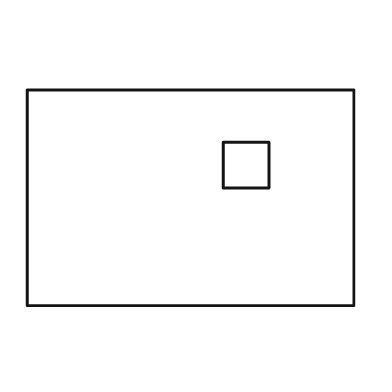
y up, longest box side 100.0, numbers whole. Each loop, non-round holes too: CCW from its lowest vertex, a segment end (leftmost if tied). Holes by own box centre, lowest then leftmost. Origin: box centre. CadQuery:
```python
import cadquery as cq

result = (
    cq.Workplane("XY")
    .moveTo(-50.0, -33.0)
    .lineTo(50.0, -33.0)
    .lineTo(50.0, 33.0)
    .lineTo(-50.0, 33.0)
    .close()
    .moveTo(10.0, 3.0)
    .lineTo(24.0, 3.0)
    .lineTo(24.0, 17.0)
    .lineTo(10.0, 17.0)
    .close()
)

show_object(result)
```